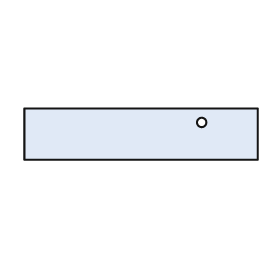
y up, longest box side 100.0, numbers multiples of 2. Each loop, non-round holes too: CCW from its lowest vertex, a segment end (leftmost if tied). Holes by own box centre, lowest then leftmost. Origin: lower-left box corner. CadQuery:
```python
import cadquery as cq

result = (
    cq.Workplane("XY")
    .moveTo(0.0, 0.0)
    .lineTo(100.0, 0.0)
    .lineTo(100.0, 22.0)
    .lineTo(0.0, 22.0)
    .close()
    .moveTo(76.0, 16.0)
    .circle(2.0)
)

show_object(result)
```